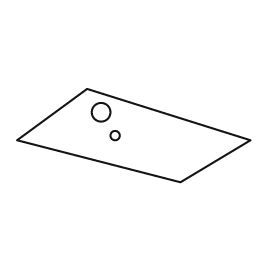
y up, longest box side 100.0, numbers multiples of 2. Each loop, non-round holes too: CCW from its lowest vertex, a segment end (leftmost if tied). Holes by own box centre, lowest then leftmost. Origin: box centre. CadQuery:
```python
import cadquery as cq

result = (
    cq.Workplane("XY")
    .moveTo(20.0, -20.0)
    .lineTo(50.0, -2.0)
    .lineTo(-20.0, 20.0)
    .lineTo(-50.0, -2.0)
    .close()
    .moveTo(-8.0, 0.0)
    .circle(2.0)
    .moveTo(-14.0, 10.0)
    .circle(4.0)
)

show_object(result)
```